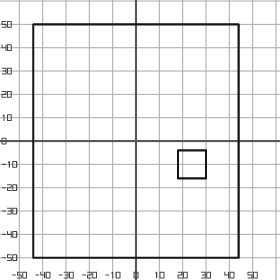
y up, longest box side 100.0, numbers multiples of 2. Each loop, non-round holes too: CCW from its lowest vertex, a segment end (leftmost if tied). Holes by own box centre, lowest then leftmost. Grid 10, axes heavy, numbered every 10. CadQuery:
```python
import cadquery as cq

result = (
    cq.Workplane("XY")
    .moveTo(-44.0, -50.0)
    .lineTo(44.0, -50.0)
    .lineTo(44.0, 50.0)
    .lineTo(-44.0, 50.0)
    .close()
    .moveTo(18.0, -16.0)
    .lineTo(30.0, -16.0)
    .lineTo(30.0, -4.0)
    .lineTo(18.0, -4.0)
    .close()
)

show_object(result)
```